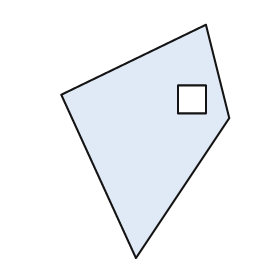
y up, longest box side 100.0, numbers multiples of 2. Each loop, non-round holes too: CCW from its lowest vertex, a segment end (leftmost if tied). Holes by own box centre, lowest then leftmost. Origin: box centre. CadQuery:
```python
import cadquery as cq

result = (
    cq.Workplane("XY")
    .moveTo(-4.0, -50.0)
    .lineTo(36.0, 10.0)
    .lineTo(26.0, 50.0)
    .lineTo(-36.0, 20.0)
    .close()
    .moveTo(14.0, 12.0)
    .lineTo(26.0, 12.0)
    .lineTo(26.0, 24.0)
    .lineTo(14.0, 24.0)
    .close()
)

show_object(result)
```